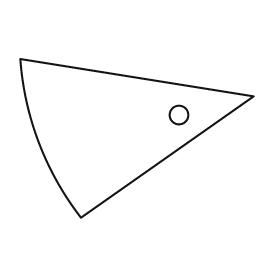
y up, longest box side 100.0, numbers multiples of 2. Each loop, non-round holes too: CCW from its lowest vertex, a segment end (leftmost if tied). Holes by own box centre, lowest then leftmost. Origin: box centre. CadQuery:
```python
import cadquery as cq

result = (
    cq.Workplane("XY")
    .moveTo(-24.0, -34.0)
    .lineTo(50.0, 18.0)
    .lineTo(-50.0, 34.0)
    .threePointArc((-42.0, -2.0), (-24.0, -34.0))
    .close()
    .moveTo(18.0, 10.0)
    .circle(4.0)
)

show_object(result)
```